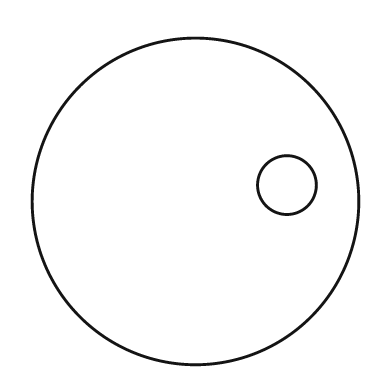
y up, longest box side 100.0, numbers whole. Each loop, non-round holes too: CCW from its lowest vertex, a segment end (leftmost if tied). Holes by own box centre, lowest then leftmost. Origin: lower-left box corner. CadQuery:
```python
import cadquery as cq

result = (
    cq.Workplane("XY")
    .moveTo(50.0, 50.0)
    .circle(50.0)
    .moveTo(78.0, 55.0)
    .circle(9.0)
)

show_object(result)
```